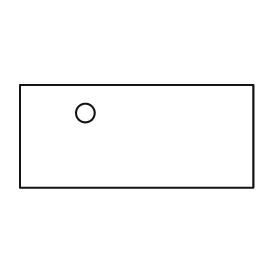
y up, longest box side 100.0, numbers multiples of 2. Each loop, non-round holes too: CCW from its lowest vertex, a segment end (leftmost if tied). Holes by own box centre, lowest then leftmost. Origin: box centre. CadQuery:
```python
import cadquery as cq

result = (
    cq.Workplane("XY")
    .moveTo(-50.0, -22.0)
    .lineTo(50.0, -22.0)
    .lineTo(50.0, 22.0)
    .lineTo(-50.0, 22.0)
    .close()
    .moveTo(-22.0, 10.0)
    .circle(4.0)
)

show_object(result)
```